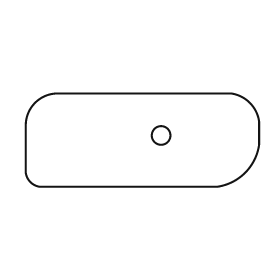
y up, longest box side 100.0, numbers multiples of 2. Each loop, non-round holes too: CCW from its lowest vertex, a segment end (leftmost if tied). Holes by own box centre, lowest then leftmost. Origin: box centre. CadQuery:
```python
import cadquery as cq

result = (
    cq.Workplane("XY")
    .moveTo(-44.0, -20.0)
    .lineTo(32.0, -20.0)
    .threePointArc((44.0, -14.0), (50.0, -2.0))
    .lineTo(50.0, 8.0)
    .threePointArc((46.0, 16.0), (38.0, 20.0))
    .lineTo(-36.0, 20.0)
    .threePointArc((-46.0, 16.0), (-50.0, 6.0))
    .lineTo(-50.0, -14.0)
    .threePointArc((-48.0, -18.0), (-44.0, -20.0))
    .close()
    .moveTo(8.0, 2.0)
    .circle(4.0)
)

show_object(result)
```